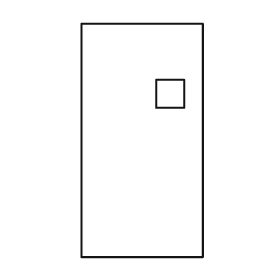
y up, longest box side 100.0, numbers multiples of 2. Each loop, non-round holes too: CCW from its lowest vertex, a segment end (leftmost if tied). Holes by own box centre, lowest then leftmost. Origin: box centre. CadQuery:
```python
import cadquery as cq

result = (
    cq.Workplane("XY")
    .moveTo(-26.0, -50.0)
    .lineTo(26.0, -50.0)
    .lineTo(26.0, 50.0)
    .lineTo(-26.0, 50.0)
    .close()
    .moveTo(6.0, 14.0)
    .lineTo(18.0, 14.0)
    .lineTo(18.0, 26.0)
    .lineTo(6.0, 26.0)
    .close()
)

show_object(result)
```